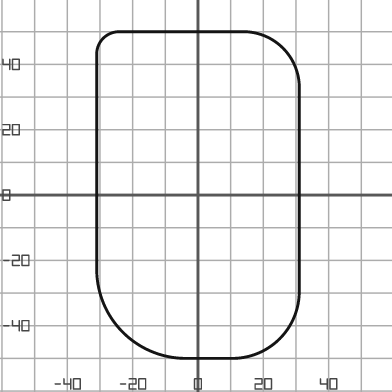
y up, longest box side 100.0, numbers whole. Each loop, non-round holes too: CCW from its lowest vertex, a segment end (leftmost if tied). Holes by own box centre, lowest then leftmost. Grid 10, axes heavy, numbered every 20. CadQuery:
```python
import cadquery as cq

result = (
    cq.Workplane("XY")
    .moveTo(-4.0, -50.0)
    .lineTo(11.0, -50.0)
    .threePointArc((25.0, -44.0), (31.0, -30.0))
    .lineTo(31.0, 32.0)
    .threePointArc((26.0, 45.0), (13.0, 50.0))
    .lineTo(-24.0, 50.0)
    .threePointArc((-29.0, 48.0), (-31.0, 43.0))
    .lineTo(-31.0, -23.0)
    .threePointArc((-23.0, -42.0), (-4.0, -50.0))
    .close()
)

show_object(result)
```